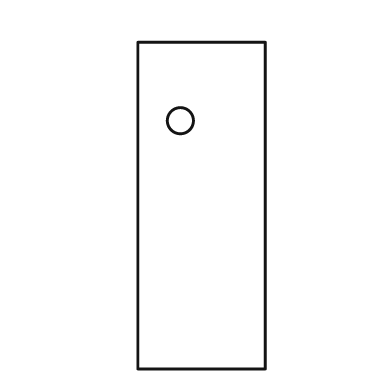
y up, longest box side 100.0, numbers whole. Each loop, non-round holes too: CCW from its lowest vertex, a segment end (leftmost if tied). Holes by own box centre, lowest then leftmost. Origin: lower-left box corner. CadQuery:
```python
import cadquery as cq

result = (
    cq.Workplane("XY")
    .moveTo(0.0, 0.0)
    .lineTo(39.0, 0.0)
    .lineTo(39.0, 100.0)
    .lineTo(0.0, 100.0)
    .close()
    .moveTo(13.0, 76.0)
    .circle(4.0)
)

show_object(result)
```